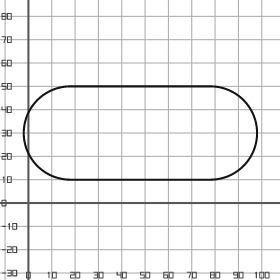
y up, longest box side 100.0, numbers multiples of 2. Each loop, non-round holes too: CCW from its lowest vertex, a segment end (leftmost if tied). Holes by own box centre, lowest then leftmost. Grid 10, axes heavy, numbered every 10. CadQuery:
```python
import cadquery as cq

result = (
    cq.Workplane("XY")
    .moveTo(18.0, 10.0)
    .lineTo(78.0, 10.0)
    .threePointArc((98.0, 30.0), (78.0, 50.0))
    .lineTo(18.0, 50.0)
    .threePointArc((-2.0, 30.0), (18.0, 10.0))
    .close()
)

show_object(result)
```